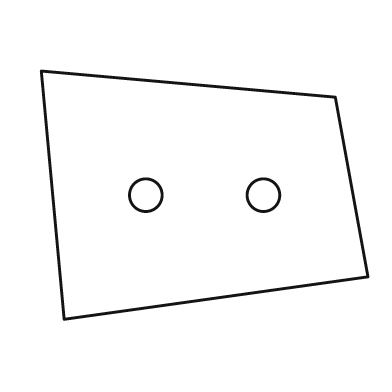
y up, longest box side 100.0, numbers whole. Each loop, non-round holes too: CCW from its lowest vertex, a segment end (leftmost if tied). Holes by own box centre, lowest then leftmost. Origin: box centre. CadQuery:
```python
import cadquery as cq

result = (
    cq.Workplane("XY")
    .moveTo(-43.0, -38.0)
    .lineTo(50.0, -25.0)
    .lineTo(40.0, 30.0)
    .lineTo(-50.0, 38.0)
    .close()
    .moveTo(-18.0, 0.0)
    .circle(5.0)
    .moveTo(18.0, 0.0)
    .circle(5.0)
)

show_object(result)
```